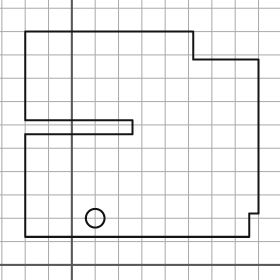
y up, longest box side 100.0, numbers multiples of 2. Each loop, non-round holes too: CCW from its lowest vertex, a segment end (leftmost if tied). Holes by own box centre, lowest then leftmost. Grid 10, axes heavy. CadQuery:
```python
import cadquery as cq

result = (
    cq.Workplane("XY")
    .moveTo(-20.0, 12.0)
    .lineTo(76.0, 12.0)
    .lineTo(76.0, 22.0)
    .lineTo(80.0, 22.0)
    .lineTo(80.0, 88.0)
    .lineTo(52.0, 88.0)
    .lineTo(52.0, 100.0)
    .lineTo(-20.0, 100.0)
    .lineTo(-20.0, 62.0)
    .lineTo(26.0, 62.0)
    .lineTo(26.0, 56.0)
    .lineTo(-20.0, 56.0)
    .close()
    .moveTo(10.0, 20.0)
    .circle(4.0)
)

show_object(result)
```